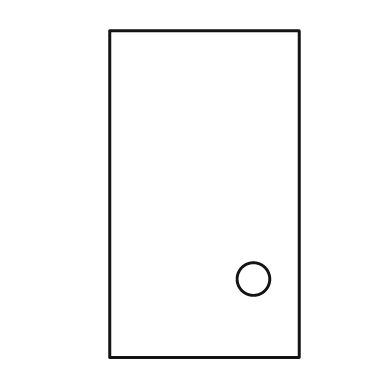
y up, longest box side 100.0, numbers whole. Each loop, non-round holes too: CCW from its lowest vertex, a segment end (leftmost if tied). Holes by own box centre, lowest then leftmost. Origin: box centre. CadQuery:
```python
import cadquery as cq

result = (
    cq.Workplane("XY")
    .moveTo(-29.0, -50.0)
    .lineTo(29.0, -50.0)
    .lineTo(29.0, 50.0)
    .lineTo(-29.0, 50.0)
    .close()
    .moveTo(15.0, -26.0)
    .circle(5.0)
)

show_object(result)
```